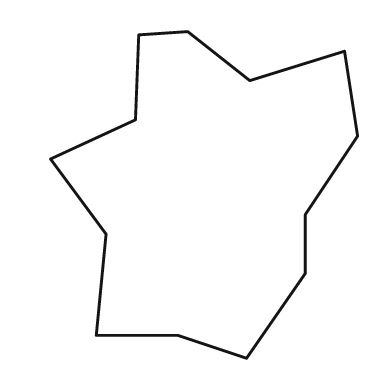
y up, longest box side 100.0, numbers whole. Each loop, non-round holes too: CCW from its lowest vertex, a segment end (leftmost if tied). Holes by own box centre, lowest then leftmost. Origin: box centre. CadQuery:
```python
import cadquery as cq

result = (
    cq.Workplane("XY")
    .moveTo(13.0, -50.0)
    .lineTo(31.0, -24.0)
    .lineTo(31.0, -6.0)
    .lineTo(47.0, 18.0)
    .lineTo(43.0, 44.0)
    .lineTo(14.0, 35.0)
    .lineTo(-5.0, 50.0)
    .lineTo(-20.0, 49.0)
    .lineTo(-21.0, 23.0)
    .lineTo(-47.0, 11.0)
    .lineTo(-30.0, -12.0)
    .lineTo(-33.0, -43.0)
    .lineTo(-8.0, -43.0)
    .close()
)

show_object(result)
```